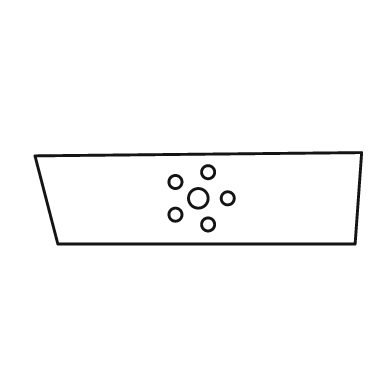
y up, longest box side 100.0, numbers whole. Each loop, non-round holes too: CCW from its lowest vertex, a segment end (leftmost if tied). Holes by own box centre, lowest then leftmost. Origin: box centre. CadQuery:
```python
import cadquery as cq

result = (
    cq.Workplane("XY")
    .moveTo(-43.0, -14.0)
    .lineTo(48.0, -14.0)
    .lineTo(50.0, 14.0)
    .lineTo(-50.0, 13.0)
    .close()
    .moveTo(3.0, -8.0)
    .circle(2.0)
    .moveTo(-7.0, -5.0)
    .circle(2.0)
    .moveTo(0.0, 0.0)
    .circle(3.0)
    .moveTo(9.0, 0.0)
    .circle(2.0)
    .moveTo(-7.0, 5.0)
    .circle(2.0)
    .moveTo(3.0, 8.0)
    .circle(2.0)
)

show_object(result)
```